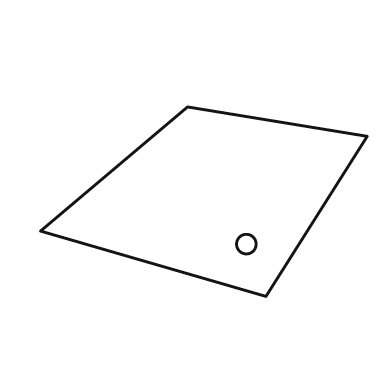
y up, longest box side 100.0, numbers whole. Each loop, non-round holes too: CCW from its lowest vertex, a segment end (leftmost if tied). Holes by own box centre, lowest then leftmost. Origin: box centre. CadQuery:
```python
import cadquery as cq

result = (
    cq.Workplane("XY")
    .moveTo(19.0, -29.0)
    .lineTo(50.0, 20.0)
    .lineTo(-5.0, 29.0)
    .lineTo(-50.0, -9.0)
    .close()
    .moveTo(13.0, -13.0)
    .circle(3.0)
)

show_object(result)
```